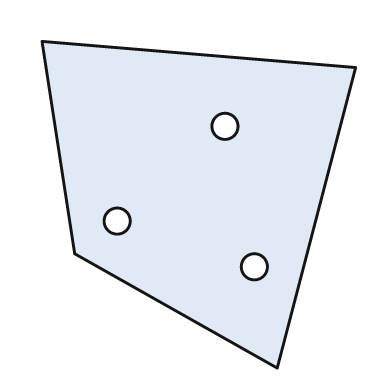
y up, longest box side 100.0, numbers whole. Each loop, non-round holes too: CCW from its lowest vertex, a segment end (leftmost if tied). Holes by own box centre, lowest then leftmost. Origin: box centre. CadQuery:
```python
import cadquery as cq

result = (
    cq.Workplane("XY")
    .moveTo(24.0, -50.0)
    .lineTo(48.0, 42.0)
    .lineTo(-48.0, 50.0)
    .lineTo(-38.0, -15.0)
    .close()
    .moveTo(17.0, -19.0)
    .circle(4.0)
    .moveTo(-25.0, -5.0)
    .circle(4.0)
    .moveTo(8.0, 24.0)
    .circle(4.0)
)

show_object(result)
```